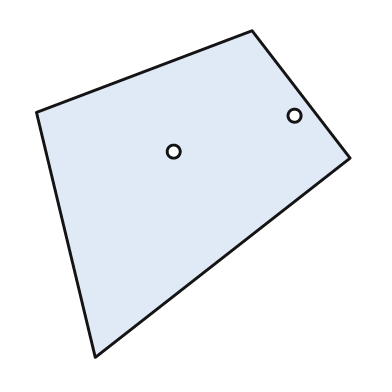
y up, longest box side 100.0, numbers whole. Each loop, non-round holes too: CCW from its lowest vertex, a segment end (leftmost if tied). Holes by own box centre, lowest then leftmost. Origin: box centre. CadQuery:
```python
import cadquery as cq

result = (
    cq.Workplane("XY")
    .moveTo(-30.0, -50.0)
    .lineTo(48.0, 11.0)
    .lineTo(18.0, 50.0)
    .lineTo(-48.0, 25.0)
    .close()
    .moveTo(-6.0, 13.0)
    .circle(2.0)
    .moveTo(31.0, 24.0)
    .circle(2.0)
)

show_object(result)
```